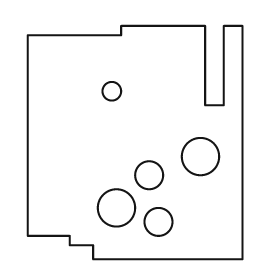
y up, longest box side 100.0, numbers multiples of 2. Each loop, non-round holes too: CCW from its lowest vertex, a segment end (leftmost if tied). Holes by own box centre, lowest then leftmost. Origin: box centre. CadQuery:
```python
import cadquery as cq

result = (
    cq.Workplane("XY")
    .moveTo(-18.0, -50.0)
    .lineTo(46.0, -50.0)
    .lineTo(46.0, 50.0)
    .lineTo(38.0, 50.0)
    .lineTo(38.0, 16.0)
    .lineTo(30.0, 16.0)
    .lineTo(30.0, 50.0)
    .lineTo(-6.0, 50.0)
    .lineTo(-6.0, 46.0)
    .lineTo(-46.0, 46.0)
    .lineTo(-46.0, -40.0)
    .lineTo(-28.0, -40.0)
    .lineTo(-28.0, -44.0)
    .lineTo(-18.0, -44.0)
    .close()
    .moveTo(10.0, -34.0)
    .circle(6.0)
    .moveTo(-8.0, -28.0)
    .circle(8.0)
    .moveTo(6.0, -14.0)
    .circle(6.0)
    .moveTo(28.0, -6.0)
    .circle(8.0)
    .moveTo(-10.0, 22.0)
    .circle(4.0)
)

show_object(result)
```